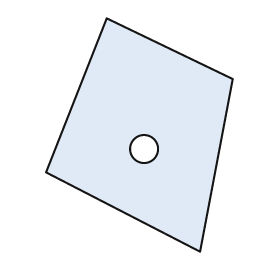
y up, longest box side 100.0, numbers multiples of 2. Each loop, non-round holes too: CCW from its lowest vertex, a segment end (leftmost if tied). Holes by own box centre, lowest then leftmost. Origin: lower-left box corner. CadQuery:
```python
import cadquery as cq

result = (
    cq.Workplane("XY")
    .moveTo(66.0, 0.0)
    .lineTo(80.0, 74.0)
    .lineTo(26.0, 100.0)
    .lineTo(0.0, 34.0)
    .close()
    .moveTo(42.0, 44.0)
    .circle(6.0)
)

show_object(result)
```